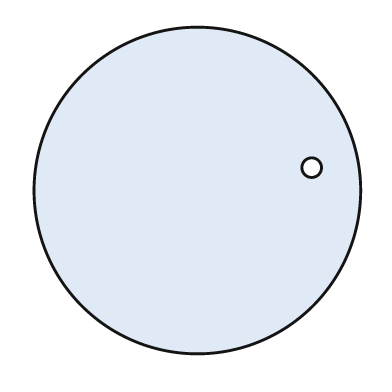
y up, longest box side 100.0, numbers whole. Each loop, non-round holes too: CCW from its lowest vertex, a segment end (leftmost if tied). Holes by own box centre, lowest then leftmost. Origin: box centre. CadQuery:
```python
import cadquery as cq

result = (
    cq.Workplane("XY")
    .moveTo(0.0, 0.0)
    .circle(50.0)
    .moveTo(35.0, 7.0)
    .circle(3.0)
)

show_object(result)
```